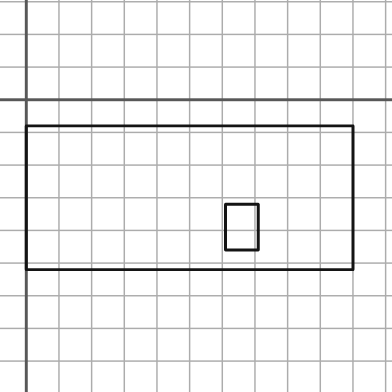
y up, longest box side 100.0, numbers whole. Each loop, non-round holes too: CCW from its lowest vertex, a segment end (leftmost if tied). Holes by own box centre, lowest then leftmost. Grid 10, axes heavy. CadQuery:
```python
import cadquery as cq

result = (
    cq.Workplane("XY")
    .moveTo(0.0, -52.0)
    .lineTo(100.0, -52.0)
    .lineTo(100.0, -8.0)
    .lineTo(0.0, -8.0)
    .close()
    .moveTo(61.0, -46.0)
    .lineTo(71.0, -46.0)
    .lineTo(71.0, -32.0)
    .lineTo(61.0, -32.0)
    .close()
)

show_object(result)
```